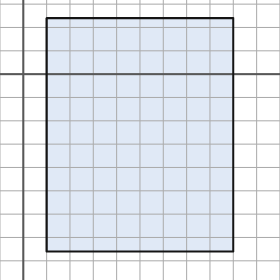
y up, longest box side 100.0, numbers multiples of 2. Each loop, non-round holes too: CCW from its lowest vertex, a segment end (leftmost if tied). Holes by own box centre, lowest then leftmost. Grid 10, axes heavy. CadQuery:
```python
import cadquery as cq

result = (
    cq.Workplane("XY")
    .moveTo(10.0, -76.0)
    .lineTo(90.0, -76.0)
    .lineTo(90.0, 24.0)
    .lineTo(10.0, 24.0)
    .close()
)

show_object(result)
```